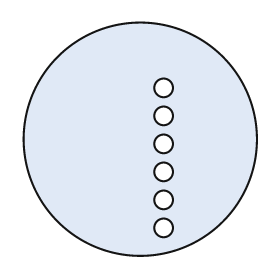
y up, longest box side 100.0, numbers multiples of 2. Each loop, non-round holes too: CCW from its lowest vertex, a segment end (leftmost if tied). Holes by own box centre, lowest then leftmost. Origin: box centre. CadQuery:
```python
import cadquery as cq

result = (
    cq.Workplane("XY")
    .moveTo(0.0, 0.0)
    .circle(50.0)
    .moveTo(10.0, -38.0)
    .circle(4.0)
    .moveTo(10.0, -26.0)
    .circle(4.0)
    .moveTo(10.0, -14.0)
    .circle(4.0)
    .moveTo(10.0, -2.0)
    .circle(4.0)
    .moveTo(10.0, 10.0)
    .circle(4.0)
    .moveTo(10.0, 22.0)
    .circle(4.0)
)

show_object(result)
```